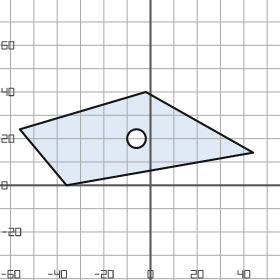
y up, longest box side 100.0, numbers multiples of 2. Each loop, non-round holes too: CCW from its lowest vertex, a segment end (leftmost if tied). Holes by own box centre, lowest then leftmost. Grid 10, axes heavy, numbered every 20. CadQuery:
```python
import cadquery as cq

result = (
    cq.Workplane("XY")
    .moveTo(-36.0, 0.0)
    .lineTo(44.0, 14.0)
    .lineTo(-2.0, 40.0)
    .lineTo(-56.0, 24.0)
    .close()
    .moveTo(-6.0, 20.0)
    .circle(4.0)
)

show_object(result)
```